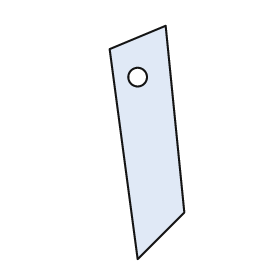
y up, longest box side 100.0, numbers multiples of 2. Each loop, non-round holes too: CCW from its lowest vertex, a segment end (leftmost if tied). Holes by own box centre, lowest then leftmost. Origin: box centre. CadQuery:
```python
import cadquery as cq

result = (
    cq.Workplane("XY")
    .moveTo(-4.0, -50.0)
    .lineTo(16.0, -30.0)
    .lineTo(8.0, 50.0)
    .lineTo(-16.0, 40.0)
    .close()
    .moveTo(-4.0, 28.0)
    .circle(4.0)
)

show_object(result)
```